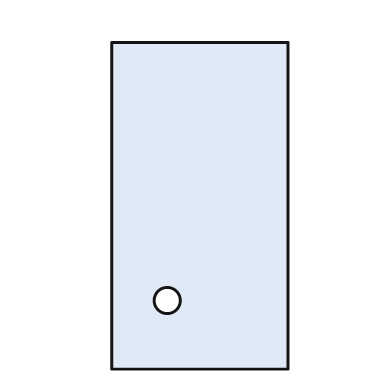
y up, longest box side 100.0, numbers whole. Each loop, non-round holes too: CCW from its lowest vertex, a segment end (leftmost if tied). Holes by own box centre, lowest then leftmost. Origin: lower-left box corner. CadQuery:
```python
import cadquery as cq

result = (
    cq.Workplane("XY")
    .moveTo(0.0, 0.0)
    .lineTo(54.0, 0.0)
    .lineTo(54.0, 100.0)
    .lineTo(0.0, 100.0)
    .close()
    .moveTo(17.0, 21.0)
    .circle(4.0)
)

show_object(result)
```